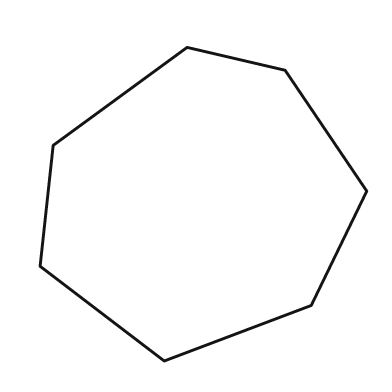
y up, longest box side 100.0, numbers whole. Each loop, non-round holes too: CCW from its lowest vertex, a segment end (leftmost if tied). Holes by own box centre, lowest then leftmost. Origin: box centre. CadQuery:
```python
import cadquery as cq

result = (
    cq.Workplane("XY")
    .moveTo(-12.0, -48.0)
    .lineTo(33.0, -31.0)
    .lineTo(50.0, 4.0)
    .lineTo(25.0, 41.0)
    .lineTo(-5.0, 48.0)
    .lineTo(-46.0, 18.0)
    .lineTo(-50.0, -19.0)
    .close()
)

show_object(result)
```